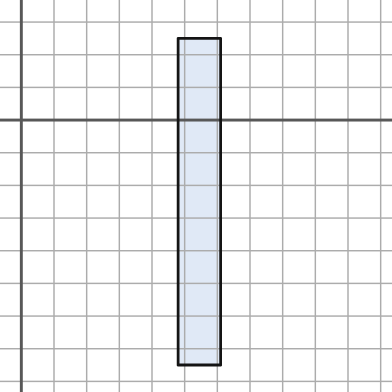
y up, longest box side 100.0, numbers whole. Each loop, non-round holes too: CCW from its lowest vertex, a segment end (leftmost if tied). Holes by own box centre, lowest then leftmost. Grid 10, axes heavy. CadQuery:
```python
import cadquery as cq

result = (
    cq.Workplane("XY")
    .moveTo(48.0, -75.0)
    .lineTo(61.0, -75.0)
    .lineTo(61.0, 25.0)
    .lineTo(48.0, 25.0)
    .close()
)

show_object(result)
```